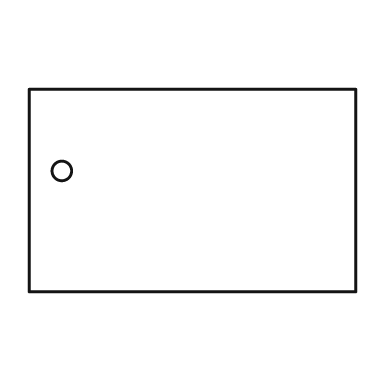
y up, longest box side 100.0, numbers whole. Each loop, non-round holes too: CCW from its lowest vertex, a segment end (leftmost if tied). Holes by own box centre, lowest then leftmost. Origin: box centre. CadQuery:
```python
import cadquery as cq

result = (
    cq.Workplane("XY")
    .moveTo(-50.0, -31.0)
    .lineTo(50.0, -31.0)
    .lineTo(50.0, 31.0)
    .lineTo(-50.0, 31.0)
    .close()
    .moveTo(-40.0, 6.0)
    .circle(3.0)
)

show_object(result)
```